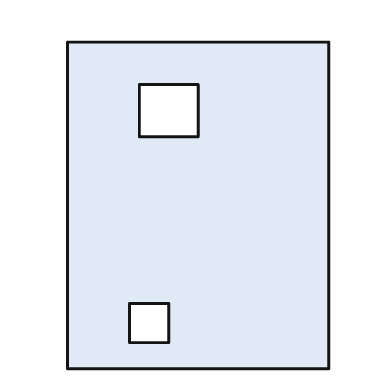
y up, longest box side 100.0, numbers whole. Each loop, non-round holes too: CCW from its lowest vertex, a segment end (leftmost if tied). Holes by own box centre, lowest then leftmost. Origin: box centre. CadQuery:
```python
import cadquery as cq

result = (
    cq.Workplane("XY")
    .moveTo(-40.0, -50.0)
    .lineTo(40.0, -50.0)
    .lineTo(40.0, 50.0)
    .lineTo(-40.0, 50.0)
    .close()
    .moveTo(-21.0, -42.0)
    .lineTo(-9.0, -42.0)
    .lineTo(-9.0, -30.0)
    .lineTo(-21.0, -30.0)
    .close()
    .moveTo(-18.0, 21.0)
    .lineTo(0.0, 21.0)
    .lineTo(0.0, 37.0)
    .lineTo(-18.0, 37.0)
    .close()
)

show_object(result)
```